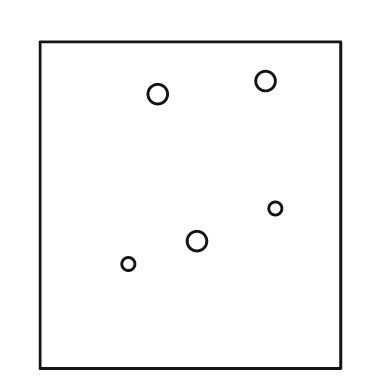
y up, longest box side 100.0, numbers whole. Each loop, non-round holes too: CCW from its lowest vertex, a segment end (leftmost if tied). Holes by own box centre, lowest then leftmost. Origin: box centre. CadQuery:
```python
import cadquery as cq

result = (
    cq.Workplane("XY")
    .moveTo(-46.0, -50.0)
    .lineTo(46.0, -50.0)
    .lineTo(46.0, 50.0)
    .lineTo(-46.0, 50.0)
    .close()
    .moveTo(-19.0, -18.0)
    .circle(2.0)
    .moveTo(2.0, -11.0)
    .circle(3.0)
    .moveTo(26.0, -1.0)
    .circle(2.0)
    .moveTo(-10.0, 34.0)
    .circle(3.0)
    .moveTo(23.0, 38.0)
    .circle(3.0)
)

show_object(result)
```